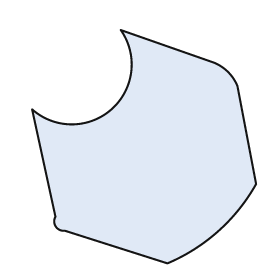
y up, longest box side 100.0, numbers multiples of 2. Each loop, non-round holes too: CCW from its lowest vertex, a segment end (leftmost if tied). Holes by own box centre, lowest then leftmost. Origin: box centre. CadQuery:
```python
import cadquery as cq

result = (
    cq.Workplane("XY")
    .moveTo(10.0, -50.0)
    .threePointArc((32.0, -36.0), (48.0, -16.0))
    .lineTo(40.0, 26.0)
    .threePointArc((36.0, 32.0), (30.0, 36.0))
    .lineTo(-10.0, 50.0)
    .threePointArc((-14.0, 16.0), (-48.0, 16.0))
    .lineTo(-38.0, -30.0)
    .threePointArc((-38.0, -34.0), (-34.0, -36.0))
    .close()
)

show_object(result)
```